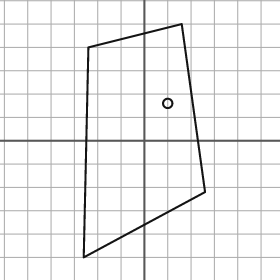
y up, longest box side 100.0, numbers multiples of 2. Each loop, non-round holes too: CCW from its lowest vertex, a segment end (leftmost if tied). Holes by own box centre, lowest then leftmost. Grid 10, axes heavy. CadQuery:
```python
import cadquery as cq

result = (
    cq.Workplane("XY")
    .moveTo(-26.0, -50.0)
    .lineTo(26.0, -22.0)
    .lineTo(16.0, 50.0)
    .lineTo(-24.0, 40.0)
    .close()
    .moveTo(10.0, 16.0)
    .circle(2.0)
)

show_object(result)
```